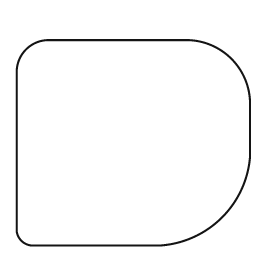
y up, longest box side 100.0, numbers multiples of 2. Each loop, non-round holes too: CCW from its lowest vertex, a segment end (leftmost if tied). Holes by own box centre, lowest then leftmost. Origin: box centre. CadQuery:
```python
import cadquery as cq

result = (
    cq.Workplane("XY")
    .moveTo(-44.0, -44.0)
    .lineTo(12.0, -44.0)
    .threePointArc((38.0, -32.0), (50.0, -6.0))
    .lineTo(50.0, 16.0)
    .threePointArc((42.0, 36.0), (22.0, 44.0))
    .lineTo(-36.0, 44.0)
    .threePointArc((-46.0, 40.0), (-50.0, 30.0))
    .lineTo(-50.0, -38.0)
    .threePointArc((-48.0, -42.0), (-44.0, -44.0))
    .close()
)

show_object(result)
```